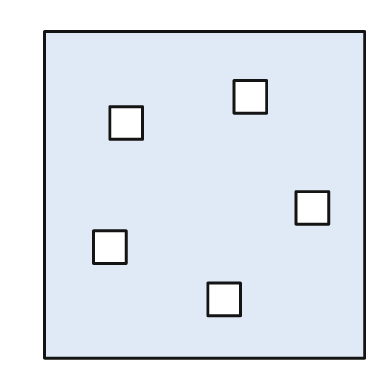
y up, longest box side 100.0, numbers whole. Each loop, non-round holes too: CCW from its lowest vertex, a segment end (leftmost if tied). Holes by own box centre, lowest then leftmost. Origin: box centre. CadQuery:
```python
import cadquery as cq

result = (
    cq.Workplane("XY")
    .moveTo(-49.0, -50.0)
    .lineTo(49.0, -50.0)
    .lineTo(49.0, 50.0)
    .lineTo(-49.0, 50.0)
    .close()
    .moveTo(1.0, -37.0)
    .lineTo(11.0, -37.0)
    .lineTo(11.0, -27.0)
    .lineTo(1.0, -27.0)
    .close()
    .moveTo(-34.0, -21.0)
    .lineTo(-24.0, -21.0)
    .lineTo(-24.0, -11.0)
    .lineTo(-34.0, -11.0)
    .close()
    .moveTo(28.0, -9.0)
    .lineTo(38.0, -9.0)
    .lineTo(38.0, 1.0)
    .lineTo(28.0, 1.0)
    .close()
    .moveTo(-29.0, 17.0)
    .lineTo(-19.0, 17.0)
    .lineTo(-19.0, 27.0)
    .lineTo(-29.0, 27.0)
    .close()
    .moveTo(9.0, 25.0)
    .lineTo(19.0, 25.0)
    .lineTo(19.0, 35.0)
    .lineTo(9.0, 35.0)
    .close()
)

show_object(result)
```